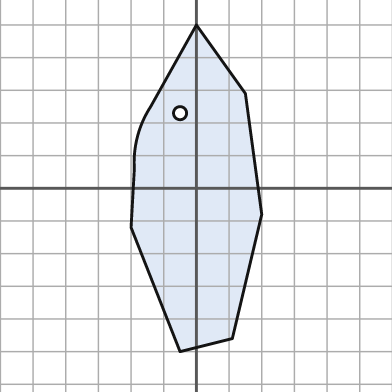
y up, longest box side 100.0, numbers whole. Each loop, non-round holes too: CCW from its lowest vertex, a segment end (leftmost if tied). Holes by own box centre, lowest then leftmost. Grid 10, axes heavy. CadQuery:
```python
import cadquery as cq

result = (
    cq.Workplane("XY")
    .moveTo(-5.0, -50.0)
    .lineTo(11.0, -46.0)
    .lineTo(20.0, -8.0)
    .lineTo(15.0, 29.0)
    .lineTo(0.0, 50.0)
    .lineTo(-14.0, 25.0)
    .threePointArc((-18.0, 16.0), (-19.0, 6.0))
    .lineTo(-20.0, -12.0)
    .close()
    .moveTo(-5.0, 23.0)
    .circle(2.0)
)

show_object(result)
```